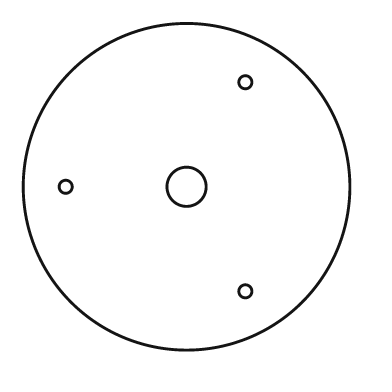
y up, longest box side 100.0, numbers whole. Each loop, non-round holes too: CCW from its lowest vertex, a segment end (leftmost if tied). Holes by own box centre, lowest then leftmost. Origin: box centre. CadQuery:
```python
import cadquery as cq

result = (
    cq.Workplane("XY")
    .moveTo(0.0, 0.0)
    .circle(50.0)
    .moveTo(18.0, -32.0)
    .circle(2.0)
    .moveTo(-37.0, 0.0)
    .circle(2.0)
    .moveTo(0.0, 0.0)
    .circle(6.0)
    .moveTo(18.0, 32.0)
    .circle(2.0)
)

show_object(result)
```